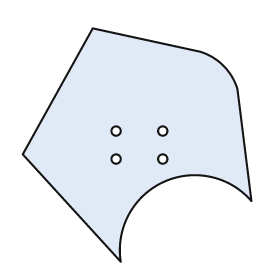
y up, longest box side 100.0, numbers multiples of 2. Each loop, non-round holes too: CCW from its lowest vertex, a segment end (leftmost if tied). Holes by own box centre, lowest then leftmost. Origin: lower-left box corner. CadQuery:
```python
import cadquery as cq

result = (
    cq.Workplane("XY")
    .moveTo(42.0, 0.0)
    .threePointArc((60.0, 34.0), (98.0, 26.0))
    .lineTo(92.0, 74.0)
    .threePointArc((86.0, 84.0), (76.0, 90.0))
    .lineTo(30.0, 100.0)
    .lineTo(0.0, 46.0)
    .close()
    .moveTo(40.0, 44.0)
    .circle(2.0)
    .moveTo(60.0, 44.0)
    .circle(2.0)
    .moveTo(40.0, 56.0)
    .circle(2.0)
    .moveTo(60.0, 56.0)
    .circle(2.0)
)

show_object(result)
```